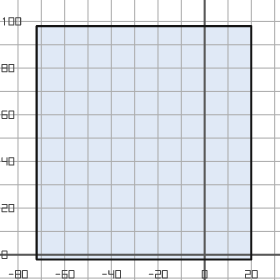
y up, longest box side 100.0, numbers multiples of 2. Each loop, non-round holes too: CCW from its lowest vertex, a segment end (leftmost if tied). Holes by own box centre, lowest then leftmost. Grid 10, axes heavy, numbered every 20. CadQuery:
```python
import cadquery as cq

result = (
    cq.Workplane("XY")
    .moveTo(-72.0, -2.0)
    .lineTo(20.0, -2.0)
    .lineTo(20.0, 98.0)
    .lineTo(-72.0, 98.0)
    .close()
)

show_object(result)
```